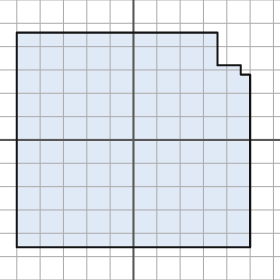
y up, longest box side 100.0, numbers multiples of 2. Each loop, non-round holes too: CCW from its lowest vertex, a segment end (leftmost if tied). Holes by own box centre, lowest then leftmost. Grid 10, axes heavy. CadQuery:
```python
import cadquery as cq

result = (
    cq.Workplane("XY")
    .moveTo(-50.0, -46.0)
    .lineTo(50.0, -46.0)
    .lineTo(50.0, 28.0)
    .lineTo(46.0, 28.0)
    .lineTo(46.0, 32.0)
    .lineTo(36.0, 32.0)
    .lineTo(36.0, 46.0)
    .lineTo(-50.0, 46.0)
    .close()
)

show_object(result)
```